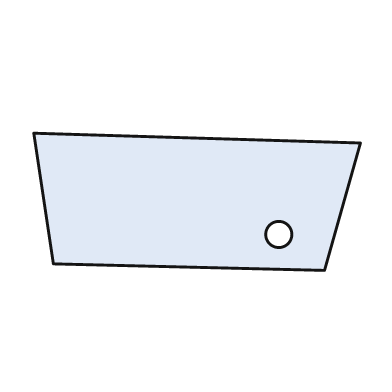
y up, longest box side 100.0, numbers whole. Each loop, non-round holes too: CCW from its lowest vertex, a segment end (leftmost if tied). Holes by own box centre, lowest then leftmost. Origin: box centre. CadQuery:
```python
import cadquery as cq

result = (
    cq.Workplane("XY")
    .moveTo(39.0, -21.0)
    .lineTo(50.0, 18.0)
    .lineTo(-50.0, 21.0)
    .lineTo(-44.0, -19.0)
    .close()
    .moveTo(25.0, -10.0)
    .circle(4.0)
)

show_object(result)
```